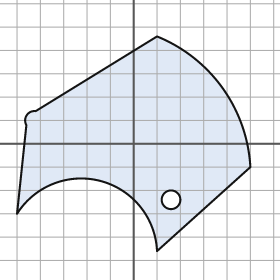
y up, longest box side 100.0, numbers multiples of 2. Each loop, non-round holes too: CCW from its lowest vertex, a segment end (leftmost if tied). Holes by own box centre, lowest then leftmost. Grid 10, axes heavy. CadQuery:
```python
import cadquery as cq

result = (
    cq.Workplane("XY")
    .moveTo(10.0, -46.0)
    .lineTo(50.0, -10.0)
    .threePointArc((38.0, 24.0), (10.0, 46.0))
    .lineTo(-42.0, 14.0)
    .threePointArc((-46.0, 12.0), (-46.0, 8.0))
    .lineTo(-50.0, -30.0)
    .threePointArc((-14.0, -16.0), (10.0, -46.0))
    .close()
    .moveTo(16.0, -24.0)
    .circle(4.0)
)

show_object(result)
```